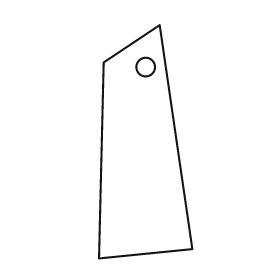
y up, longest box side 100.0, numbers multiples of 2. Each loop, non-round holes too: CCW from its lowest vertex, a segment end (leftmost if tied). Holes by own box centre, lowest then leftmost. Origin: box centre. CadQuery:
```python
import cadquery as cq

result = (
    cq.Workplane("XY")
    .moveTo(-20.0, -50.0)
    .lineTo(20.0, -46.0)
    .lineTo(6.0, 50.0)
    .lineTo(-18.0, 34.0)
    .close()
    .moveTo(0.0, 32.0)
    .circle(4.0)
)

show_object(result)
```